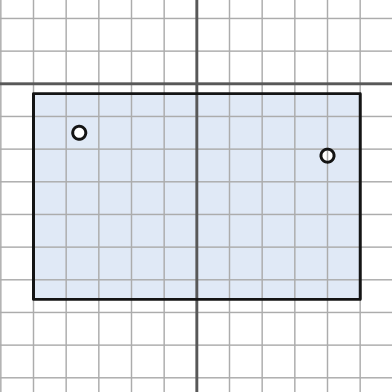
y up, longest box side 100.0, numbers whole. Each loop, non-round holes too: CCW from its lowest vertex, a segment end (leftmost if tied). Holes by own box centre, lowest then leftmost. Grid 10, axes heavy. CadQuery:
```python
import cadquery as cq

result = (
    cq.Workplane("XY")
    .moveTo(-50.0, -66.0)
    .lineTo(50.0, -66.0)
    .lineTo(50.0, -3.0)
    .lineTo(-50.0, -3.0)
    .close()
    .moveTo(40.0, -22.0)
    .circle(2.0)
    .moveTo(-36.0, -15.0)
    .circle(2.0)
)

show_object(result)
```